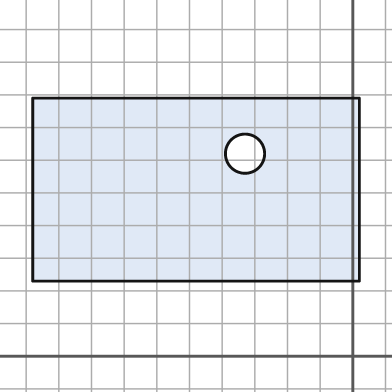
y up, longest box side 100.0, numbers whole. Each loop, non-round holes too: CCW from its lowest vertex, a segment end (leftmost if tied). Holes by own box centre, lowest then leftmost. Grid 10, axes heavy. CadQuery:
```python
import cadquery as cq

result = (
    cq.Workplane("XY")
    .moveTo(-98.0, 23.0)
    .lineTo(2.0, 23.0)
    .lineTo(2.0, 79.0)
    .lineTo(-98.0, 79.0)
    .close()
    .moveTo(-33.0, 62.0)
    .circle(6.0)
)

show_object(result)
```